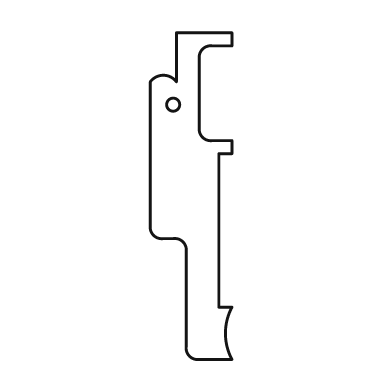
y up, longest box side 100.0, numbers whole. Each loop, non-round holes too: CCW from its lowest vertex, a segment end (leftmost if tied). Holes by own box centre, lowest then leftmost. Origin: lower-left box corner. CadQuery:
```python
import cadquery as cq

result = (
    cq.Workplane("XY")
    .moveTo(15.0, 0.0)
    .lineTo(25.0, 0.0)
    .threePointArc((23.0, 8.0), (25.0, 16.0))
    .lineTo(21.0, 16.0)
    .lineTo(21.0, 63.0)
    .lineTo(25.0, 63.0)
    .lineTo(25.0, 67.0)
    .lineTo(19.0, 67.0)
    .threePointArc((16.0, 68.0), (15.0, 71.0))
    .lineTo(15.0, 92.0)
    .threePointArc((16.0, 95.0), (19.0, 96.0))
    .lineTo(25.0, 96.0)
    .lineTo(25.0, 100.0)
    .lineTo(8.0, 100.0)
    .lineTo(8.0, 85.0)
    .threePointArc((4.0, 87.0), (0.0, 85.0))
    .lineTo(0.0, 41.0)
    .threePointArc((1.0, 38.0), (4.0, 37.0))
    .lineTo(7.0, 37.0)
    .threePointArc((10.0, 36.0), (11.0, 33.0))
    .lineTo(11.0, 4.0)
    .threePointArc((12.0, 1.0), (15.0, 0.0))
    .close()
    .moveTo(7.0, 78.0)
    .circle(2.0)
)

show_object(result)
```